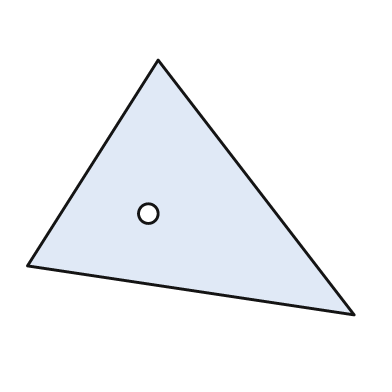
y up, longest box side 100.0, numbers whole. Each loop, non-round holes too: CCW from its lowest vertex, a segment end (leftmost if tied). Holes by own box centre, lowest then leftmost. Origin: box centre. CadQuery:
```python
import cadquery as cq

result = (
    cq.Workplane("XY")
    .moveTo(50.0, -39.0)
    .lineTo(-10.0, 39.0)
    .lineTo(-50.0, -24.0)
    .close()
    .moveTo(-13.0, -8.0)
    .circle(3.0)
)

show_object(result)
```